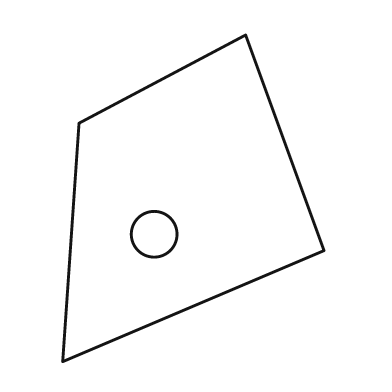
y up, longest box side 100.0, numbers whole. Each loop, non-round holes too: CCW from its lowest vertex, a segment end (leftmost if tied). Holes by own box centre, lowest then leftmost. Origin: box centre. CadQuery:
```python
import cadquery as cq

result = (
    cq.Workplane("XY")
    .moveTo(-40.0, -50.0)
    .lineTo(40.0, -16.0)
    .lineTo(16.0, 50.0)
    .lineTo(-35.0, 23.0)
    .close()
    .moveTo(-12.0, -11.0)
    .circle(7.0)
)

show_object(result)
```